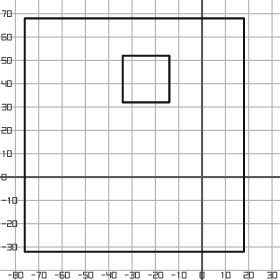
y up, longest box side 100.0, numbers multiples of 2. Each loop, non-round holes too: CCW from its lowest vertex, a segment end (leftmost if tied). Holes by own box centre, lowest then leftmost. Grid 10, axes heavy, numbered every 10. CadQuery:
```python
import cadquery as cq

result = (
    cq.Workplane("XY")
    .moveTo(-76.0, -32.0)
    .lineTo(18.0, -32.0)
    .lineTo(18.0, 68.0)
    .lineTo(-76.0, 68.0)
    .close()
    .moveTo(-34.0, 32.0)
    .lineTo(-14.0, 32.0)
    .lineTo(-14.0, 52.0)
    .lineTo(-34.0, 52.0)
    .close()
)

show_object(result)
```